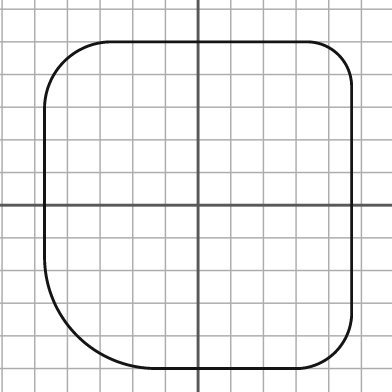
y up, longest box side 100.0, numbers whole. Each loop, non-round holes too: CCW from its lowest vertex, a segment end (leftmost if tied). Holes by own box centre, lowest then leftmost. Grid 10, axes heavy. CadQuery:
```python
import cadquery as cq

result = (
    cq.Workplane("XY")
    .moveTo(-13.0, -50.0)
    .lineTo(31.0, -50.0)
    .threePointArc((42.0, -45.0), (47.0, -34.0))
    .lineTo(47.0, 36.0)
    .threePointArc((43.0, 46.0), (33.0, 50.0))
    .lineTo(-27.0, 50.0)
    .threePointArc((-41.0, 44.0), (-47.0, 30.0))
    .lineTo(-47.0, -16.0)
    .threePointArc((-37.0, -40.0), (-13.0, -50.0))
    .close()
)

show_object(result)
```